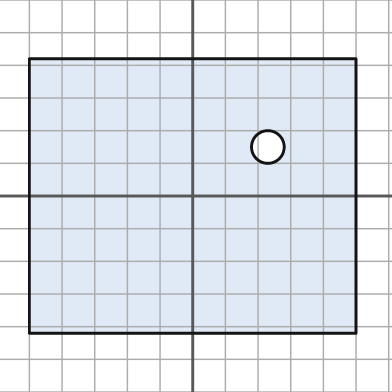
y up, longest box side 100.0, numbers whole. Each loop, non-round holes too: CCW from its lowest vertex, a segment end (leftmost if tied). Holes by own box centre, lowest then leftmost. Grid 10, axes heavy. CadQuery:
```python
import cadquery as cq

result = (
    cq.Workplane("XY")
    .moveTo(-50.0, -42.0)
    .lineTo(50.0, -42.0)
    .lineTo(50.0, 42.0)
    .lineTo(-50.0, 42.0)
    .close()
    .moveTo(23.0, 15.0)
    .circle(5.0)
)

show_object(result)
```